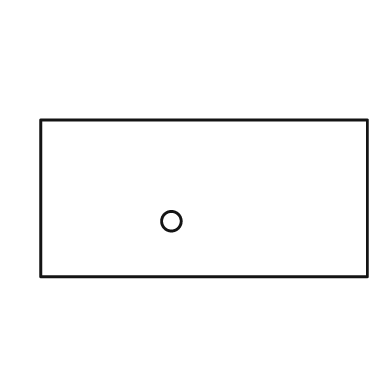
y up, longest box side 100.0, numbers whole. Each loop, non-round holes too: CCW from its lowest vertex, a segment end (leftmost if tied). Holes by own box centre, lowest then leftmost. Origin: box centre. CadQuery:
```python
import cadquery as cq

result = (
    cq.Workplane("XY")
    .moveTo(-50.0, -24.0)
    .lineTo(50.0, -24.0)
    .lineTo(50.0, 24.0)
    .lineTo(-50.0, 24.0)
    .close()
    .moveTo(-10.0, -7.0)
    .circle(3.0)
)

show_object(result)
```